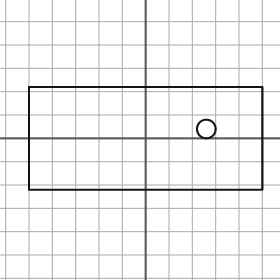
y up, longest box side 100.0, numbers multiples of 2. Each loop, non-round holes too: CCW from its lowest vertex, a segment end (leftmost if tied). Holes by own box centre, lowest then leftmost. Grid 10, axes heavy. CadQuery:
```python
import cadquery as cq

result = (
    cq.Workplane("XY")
    .moveTo(-50.0, -22.0)
    .lineTo(50.0, -22.0)
    .lineTo(50.0, 22.0)
    .lineTo(-50.0, 22.0)
    .close()
    .moveTo(26.0, 4.0)
    .circle(4.0)
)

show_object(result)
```